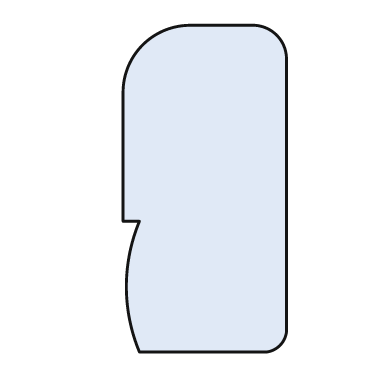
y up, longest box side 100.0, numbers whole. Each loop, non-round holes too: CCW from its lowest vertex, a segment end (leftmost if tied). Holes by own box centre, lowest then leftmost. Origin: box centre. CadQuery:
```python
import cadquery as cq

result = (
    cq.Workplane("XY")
    .moveTo(-20.0, -50.0)
    .lineTo(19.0, -50.0)
    .threePointArc((23.0, -48.0), (25.0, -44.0))
    .lineTo(25.0, 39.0)
    .threePointArc((22.0, 47.0), (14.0, 50.0))
    .lineTo(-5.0, 50.0)
    .threePointArc((-19.0, 44.0), (-25.0, 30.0))
    .lineTo(-25.0, -10.0)
    .lineTo(-20.0, -10.0)
    .threePointArc((-24.0, -30.0), (-20.0, -50.0))
    .close()
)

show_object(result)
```